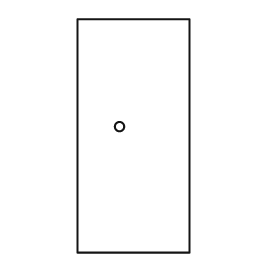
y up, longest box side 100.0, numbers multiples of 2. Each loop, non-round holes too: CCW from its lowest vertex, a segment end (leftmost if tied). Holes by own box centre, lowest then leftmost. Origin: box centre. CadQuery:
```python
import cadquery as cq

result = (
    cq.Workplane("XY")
    .moveTo(-24.0, -50.0)
    .lineTo(24.0, -50.0)
    .lineTo(24.0, 50.0)
    .lineTo(-24.0, 50.0)
    .close()
    .moveTo(-6.0, 4.0)
    .circle(2.0)
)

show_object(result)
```